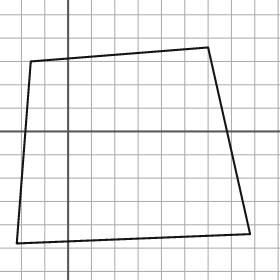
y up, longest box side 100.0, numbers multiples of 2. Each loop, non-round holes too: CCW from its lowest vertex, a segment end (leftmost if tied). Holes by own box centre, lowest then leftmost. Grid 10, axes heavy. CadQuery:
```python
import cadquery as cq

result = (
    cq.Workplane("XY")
    .moveTo(-22.0, -48.0)
    .lineTo(78.0, -44.0)
    .lineTo(60.0, 36.0)
    .lineTo(-16.0, 30.0)
    .close()
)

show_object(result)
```